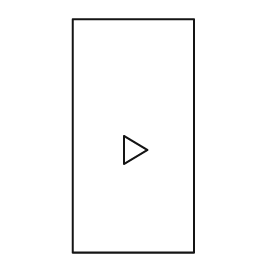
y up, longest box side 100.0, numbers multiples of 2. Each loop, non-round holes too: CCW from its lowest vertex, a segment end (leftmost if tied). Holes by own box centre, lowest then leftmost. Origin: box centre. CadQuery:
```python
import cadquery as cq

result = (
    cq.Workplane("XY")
    .moveTo(-26.0, -50.0)
    .lineTo(26.0, -50.0)
    .lineTo(26.0, 50.0)
    .lineTo(-26.0, 50.0)
    .close()
    .moveTo(-4.0, -12.0)
    .lineTo(6.0, -6.0)
    .lineTo(-4.0, 0.0)
    .close()
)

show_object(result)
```